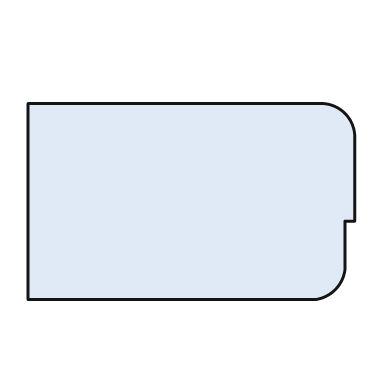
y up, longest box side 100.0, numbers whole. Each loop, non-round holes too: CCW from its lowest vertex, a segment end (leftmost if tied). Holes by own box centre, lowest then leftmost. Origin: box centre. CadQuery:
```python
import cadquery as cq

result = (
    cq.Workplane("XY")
    .moveTo(-50.0, -30.0)
    .lineTo(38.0, -30.0)
    .threePointArc((44.0, -27.0), (47.0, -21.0))
    .lineTo(47.0, -6.0)
    .lineTo(50.0, -6.0)
    .lineTo(50.0, 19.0)
    .threePointArc((47.0, 27.0), (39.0, 30.0))
    .lineTo(-50.0, 30.0)
    .close()
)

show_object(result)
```